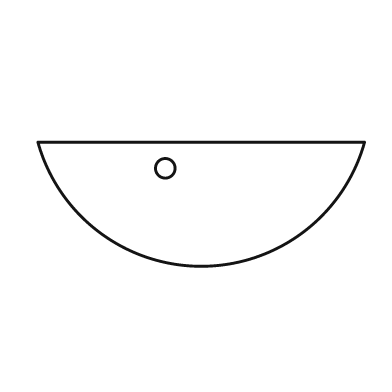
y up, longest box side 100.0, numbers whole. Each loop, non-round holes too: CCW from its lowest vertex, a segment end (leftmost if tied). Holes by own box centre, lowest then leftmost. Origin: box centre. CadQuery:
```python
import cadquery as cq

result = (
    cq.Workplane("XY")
    .moveTo(-50.0, 19.0)
    .threePointArc((0.0, -19.0), (50.0, 19.0))
    .close()
    .moveTo(-11.0, 11.0)
    .circle(3.0)
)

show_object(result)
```